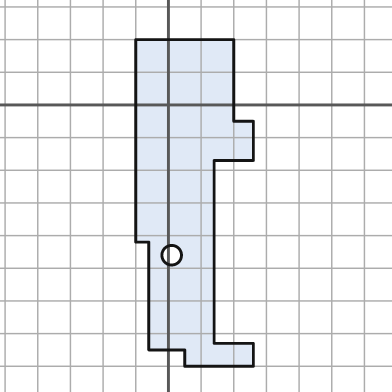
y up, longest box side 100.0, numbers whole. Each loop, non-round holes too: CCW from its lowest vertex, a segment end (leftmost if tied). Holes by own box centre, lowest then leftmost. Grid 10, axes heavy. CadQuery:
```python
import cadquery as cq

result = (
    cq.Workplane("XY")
    .moveTo(5.0, -80.0)
    .lineTo(26.0, -80.0)
    .lineTo(26.0, -73.0)
    .lineTo(14.0, -73.0)
    .lineTo(14.0, -17.0)
    .lineTo(26.0, -17.0)
    .lineTo(26.0, -5.0)
    .lineTo(20.0, -5.0)
    .lineTo(20.0, 20.0)
    .lineTo(-10.0, 20.0)
    .lineTo(-10.0, -42.0)
    .lineTo(-6.0, -42.0)
    .lineTo(-6.0, -75.0)
    .lineTo(5.0, -75.0)
    .close()
    .moveTo(1.0, -46.0)
    .circle(3.0)
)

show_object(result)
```